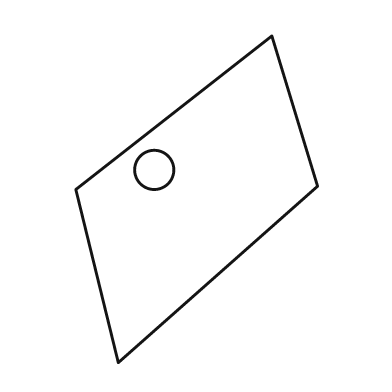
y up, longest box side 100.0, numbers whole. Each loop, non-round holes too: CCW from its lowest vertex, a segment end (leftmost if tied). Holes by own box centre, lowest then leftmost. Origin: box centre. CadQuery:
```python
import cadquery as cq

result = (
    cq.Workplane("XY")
    .moveTo(-24.0, -50.0)
    .lineTo(37.0, 4.0)
    .lineTo(23.0, 50.0)
    .lineTo(-37.0, 3.0)
    .close()
    .moveTo(-13.0, 9.0)
    .circle(6.0)
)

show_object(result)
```